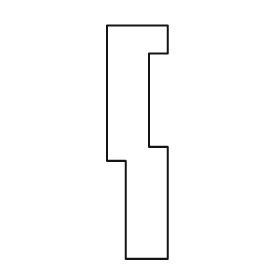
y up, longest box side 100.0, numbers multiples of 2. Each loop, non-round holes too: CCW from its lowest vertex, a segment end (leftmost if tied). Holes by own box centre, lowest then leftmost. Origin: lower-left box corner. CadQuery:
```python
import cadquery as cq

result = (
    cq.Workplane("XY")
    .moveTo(8.0, 0.0)
    .lineTo(26.0, 0.0)
    .lineTo(26.0, 48.0)
    .lineTo(18.0, 48.0)
    .lineTo(18.0, 88.0)
    .lineTo(26.0, 88.0)
    .lineTo(26.0, 100.0)
    .lineTo(0.0, 100.0)
    .lineTo(0.0, 42.0)
    .lineTo(8.0, 42.0)
    .close()
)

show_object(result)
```